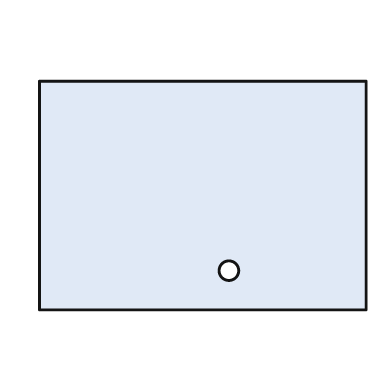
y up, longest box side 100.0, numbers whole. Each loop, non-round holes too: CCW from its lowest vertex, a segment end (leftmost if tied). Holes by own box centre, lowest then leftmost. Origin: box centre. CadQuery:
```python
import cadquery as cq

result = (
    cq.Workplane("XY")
    .moveTo(-50.0, -35.0)
    .lineTo(50.0, -35.0)
    .lineTo(50.0, 35.0)
    .lineTo(-50.0, 35.0)
    .close()
    .moveTo(8.0, -23.0)
    .circle(3.0)
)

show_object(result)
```